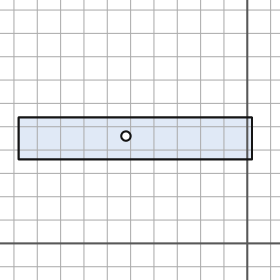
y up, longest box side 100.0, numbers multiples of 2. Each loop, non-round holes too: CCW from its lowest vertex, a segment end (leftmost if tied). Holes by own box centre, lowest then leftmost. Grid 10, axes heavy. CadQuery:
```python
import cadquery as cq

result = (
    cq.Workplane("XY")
    .moveTo(-98.0, 36.0)
    .lineTo(2.0, 36.0)
    .lineTo(2.0, 54.0)
    .lineTo(-98.0, 54.0)
    .close()
    .moveTo(-52.0, 46.0)
    .circle(2.0)
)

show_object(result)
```